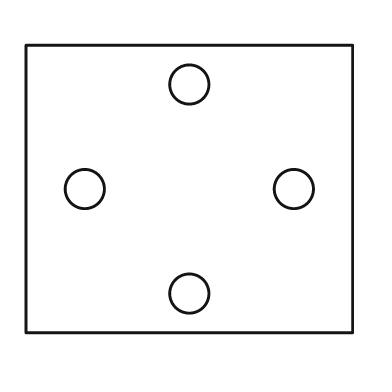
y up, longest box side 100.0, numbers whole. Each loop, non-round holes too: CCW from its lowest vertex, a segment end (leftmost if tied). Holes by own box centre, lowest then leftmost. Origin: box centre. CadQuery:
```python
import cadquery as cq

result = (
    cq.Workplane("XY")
    .moveTo(-50.0, -44.0)
    .lineTo(50.0, -44.0)
    .lineTo(50.0, 44.0)
    .lineTo(-50.0, 44.0)
    .close()
    .moveTo(0.0, -32.0)
    .circle(6.0)
    .moveTo(-32.0, 0.0)
    .circle(6.0)
    .moveTo(32.0, 0.0)
    .circle(6.0)
    .moveTo(0.0, 32.0)
    .circle(6.0)
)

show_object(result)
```